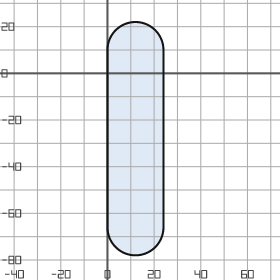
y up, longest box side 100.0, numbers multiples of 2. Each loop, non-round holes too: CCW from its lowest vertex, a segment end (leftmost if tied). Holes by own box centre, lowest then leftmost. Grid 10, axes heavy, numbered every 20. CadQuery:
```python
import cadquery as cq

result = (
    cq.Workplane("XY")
    .moveTo(0.0, -66.0)
    .threePointArc((12.0, -78.0), (24.0, -66.0))
    .lineTo(24.0, 10.0)
    .threePointArc((12.0, 22.0), (0.0, 10.0))
    .close()
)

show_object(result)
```